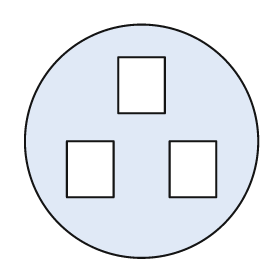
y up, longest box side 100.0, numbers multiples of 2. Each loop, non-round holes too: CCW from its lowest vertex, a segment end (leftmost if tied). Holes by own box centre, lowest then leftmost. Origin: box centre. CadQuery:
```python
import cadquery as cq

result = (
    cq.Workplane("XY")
    .moveTo(0.0, 0.0)
    .circle(50.0)
    .moveTo(-32.0, -24.0)
    .lineTo(-12.0, -24.0)
    .lineTo(-12.0, 0.0)
    .lineTo(-32.0, 0.0)
    .close()
    .moveTo(12.0, -24.0)
    .lineTo(32.0, -24.0)
    .lineTo(32.0, 0.0)
    .lineTo(12.0, 0.0)
    .close()
    .moveTo(-10.0, 12.0)
    .lineTo(10.0, 12.0)
    .lineTo(10.0, 36.0)
    .lineTo(-10.0, 36.0)
    .close()
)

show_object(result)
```